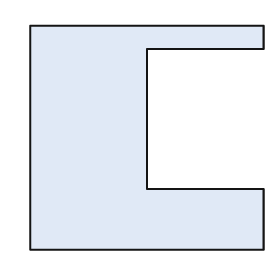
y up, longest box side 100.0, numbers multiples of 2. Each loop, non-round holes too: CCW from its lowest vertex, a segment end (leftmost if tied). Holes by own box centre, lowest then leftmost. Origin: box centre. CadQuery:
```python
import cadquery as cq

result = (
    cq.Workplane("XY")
    .moveTo(-50.0, -48.0)
    .lineTo(50.0, -48.0)
    .lineTo(50.0, -22.0)
    .lineTo(0.0, -22.0)
    .lineTo(0.0, 38.0)
    .lineTo(50.0, 38.0)
    .lineTo(50.0, 48.0)
    .lineTo(-50.0, 48.0)
    .close()
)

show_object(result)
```